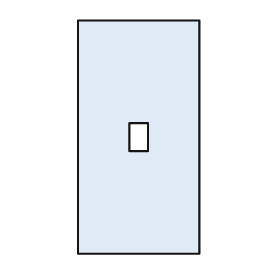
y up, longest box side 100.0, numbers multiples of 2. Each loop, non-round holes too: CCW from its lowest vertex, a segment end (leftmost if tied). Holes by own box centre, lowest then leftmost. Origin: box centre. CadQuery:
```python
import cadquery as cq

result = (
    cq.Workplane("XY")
    .moveTo(-26.0, -50.0)
    .lineTo(26.0, -50.0)
    .lineTo(26.0, 50.0)
    .lineTo(-26.0, 50.0)
    .close()
    .moveTo(-4.0, -6.0)
    .lineTo(4.0, -6.0)
    .lineTo(4.0, 6.0)
    .lineTo(-4.0, 6.0)
    .close()
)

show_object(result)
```